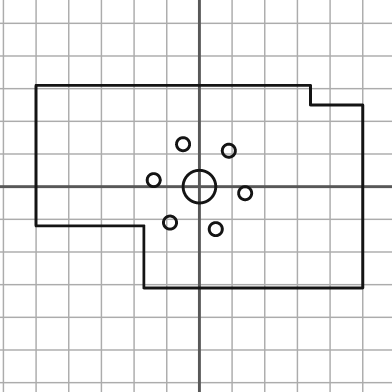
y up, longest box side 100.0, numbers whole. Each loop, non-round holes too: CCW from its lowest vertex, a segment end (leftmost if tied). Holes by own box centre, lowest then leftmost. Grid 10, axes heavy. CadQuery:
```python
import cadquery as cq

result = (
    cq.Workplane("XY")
    .moveTo(-17.0, -31.0)
    .lineTo(50.0, -31.0)
    .lineTo(50.0, 25.0)
    .lineTo(34.0, 25.0)
    .lineTo(34.0, 31.0)
    .lineTo(-50.0, 31.0)
    .lineTo(-50.0, -12.0)
    .lineTo(-17.0, -12.0)
    .close()
    .moveTo(5.0, -13.0)
    .circle(2.0)
    .moveTo(-9.0, -11.0)
    .circle(2.0)
    .moveTo(14.0, -2.0)
    .circle(2.0)
    .moveTo(0.0, 0.0)
    .circle(5.0)
    .moveTo(-14.0, 2.0)
    .circle(2.0)
    .moveTo(9.0, 11.0)
    .circle(2.0)
    .moveTo(-5.0, 13.0)
    .circle(2.0)
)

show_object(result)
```